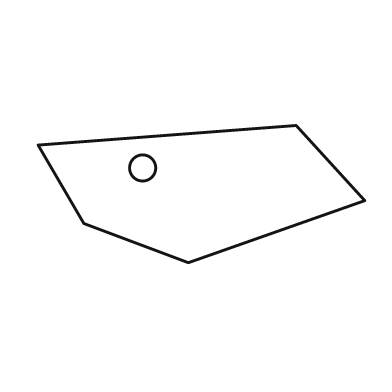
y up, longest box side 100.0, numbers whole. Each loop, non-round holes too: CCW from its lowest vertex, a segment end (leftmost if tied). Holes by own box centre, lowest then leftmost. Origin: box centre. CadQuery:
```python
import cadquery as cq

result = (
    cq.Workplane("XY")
    .moveTo(-4.0, -21.0)
    .lineTo(50.0, -2.0)
    .lineTo(29.0, 21.0)
    .lineTo(-50.0, 15.0)
    .lineTo(-36.0, -9.0)
    .close()
    .moveTo(-18.0, 8.0)
    .circle(4.0)
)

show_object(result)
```